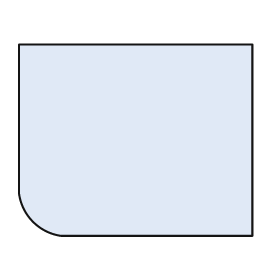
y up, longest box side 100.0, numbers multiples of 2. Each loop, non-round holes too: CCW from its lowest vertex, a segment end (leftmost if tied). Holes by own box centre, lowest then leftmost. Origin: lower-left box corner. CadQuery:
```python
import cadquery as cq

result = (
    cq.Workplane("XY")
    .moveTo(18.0, 0.0)
    .lineTo(100.0, 0.0)
    .lineTo(100.0, 82.0)
    .lineTo(0.0, 82.0)
    .lineTo(0.0, 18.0)
    .threePointArc((6.0, 6.0), (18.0, 0.0))
    .close()
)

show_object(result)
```